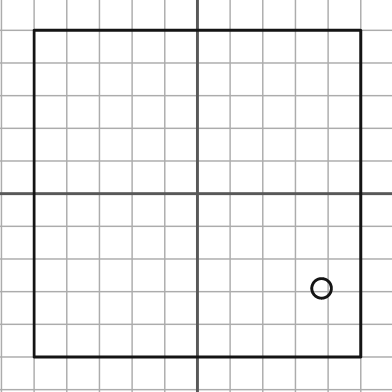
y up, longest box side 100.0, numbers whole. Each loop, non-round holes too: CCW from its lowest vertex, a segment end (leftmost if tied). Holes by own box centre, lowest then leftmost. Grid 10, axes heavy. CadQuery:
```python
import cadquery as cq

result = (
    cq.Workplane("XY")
    .moveTo(-50.0, -50.0)
    .lineTo(50.0, -50.0)
    .lineTo(50.0, 50.0)
    .lineTo(-50.0, 50.0)
    .close()
    .moveTo(38.0, -29.0)
    .circle(3.0)
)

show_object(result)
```